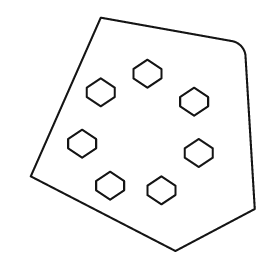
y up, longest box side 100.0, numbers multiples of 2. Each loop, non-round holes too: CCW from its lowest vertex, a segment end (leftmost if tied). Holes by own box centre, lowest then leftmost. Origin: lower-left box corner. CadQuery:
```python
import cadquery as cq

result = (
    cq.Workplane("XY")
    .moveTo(62.0, 0.0)
    .lineTo(96.0, 18.0)
    .lineTo(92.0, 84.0)
    .threePointArc((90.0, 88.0), (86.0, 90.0))
    .lineTo(30.0, 100.0)
    .lineTo(0.0, 32.0)
    .close()
    .moveTo(56.0, 20.0)
    .lineTo(62.0, 24.0)
    .lineTo(62.0, 28.0)
    .lineTo(56.0, 32.0)
    .lineTo(50.0, 28.0)
    .lineTo(50.0, 24.0)
    .close()
    .moveTo(34.0, 22.0)
    .lineTo(40.0, 26.0)
    .lineTo(40.0, 30.0)
    .lineTo(34.0, 34.0)
    .lineTo(28.0, 30.0)
    .lineTo(28.0, 26.0)
    .close()
    .moveTo(72.0, 36.0)
    .lineTo(78.0, 40.0)
    .lineTo(78.0, 44.0)
    .lineTo(72.0, 48.0)
    .lineTo(66.0, 44.0)
    .lineTo(66.0, 40.0)
    .close()
    .moveTo(22.0, 40.0)
    .lineTo(28.0, 44.0)
    .lineTo(28.0, 48.0)
    .lineTo(22.0, 52.0)
    .lineTo(16.0, 48.0)
    .lineTo(16.0, 44.0)
    .close()
    .moveTo(70.0, 58.0)
    .lineTo(76.0, 62.0)
    .lineTo(76.0, 66.0)
    .lineTo(70.0, 70.0)
    .lineTo(64.0, 66.0)
    .lineTo(64.0, 62.0)
    .close()
    .moveTo(30.0, 62.0)
    .lineTo(36.0, 66.0)
    .lineTo(36.0, 70.0)
    .lineTo(30.0, 74.0)
    .lineTo(24.0, 70.0)
    .lineTo(24.0, 66.0)
    .close()
    .moveTo(50.0, 70.0)
    .lineTo(56.0, 74.0)
    .lineTo(56.0, 78.0)
    .lineTo(50.0, 82.0)
    .lineTo(44.0, 78.0)
    .lineTo(44.0, 74.0)
    .close()
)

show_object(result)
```